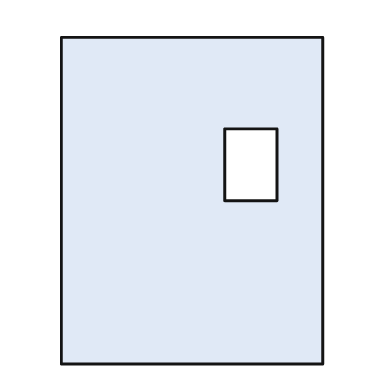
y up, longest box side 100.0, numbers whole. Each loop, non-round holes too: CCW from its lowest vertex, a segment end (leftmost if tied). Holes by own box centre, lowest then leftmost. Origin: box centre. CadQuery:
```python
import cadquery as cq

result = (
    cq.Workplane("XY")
    .moveTo(-40.0, -50.0)
    .lineTo(40.0, -50.0)
    .lineTo(40.0, 50.0)
    .lineTo(-40.0, 50.0)
    .close()
    .moveTo(10.0, 0.0)
    .lineTo(26.0, 0.0)
    .lineTo(26.0, 22.0)
    .lineTo(10.0, 22.0)
    .close()
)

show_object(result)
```